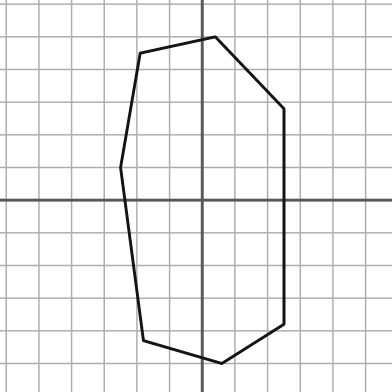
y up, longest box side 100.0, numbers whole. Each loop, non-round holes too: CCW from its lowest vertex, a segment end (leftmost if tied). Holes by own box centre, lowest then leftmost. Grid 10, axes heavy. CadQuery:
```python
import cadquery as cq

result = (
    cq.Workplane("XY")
    .moveTo(6.0, -50.0)
    .lineTo(25.0, -38.0)
    .lineTo(25.0, 28.0)
    .lineTo(4.0, 50.0)
    .lineTo(-19.0, 45.0)
    .lineTo(-25.0, 10.0)
    .lineTo(-18.0, -43.0)
    .close()
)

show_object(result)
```